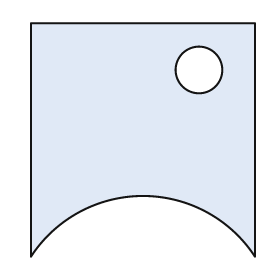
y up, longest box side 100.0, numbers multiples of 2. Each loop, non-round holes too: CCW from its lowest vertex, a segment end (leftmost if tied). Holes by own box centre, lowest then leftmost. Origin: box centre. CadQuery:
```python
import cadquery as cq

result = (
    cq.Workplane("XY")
    .moveTo(-48.0, -50.0)
    .threePointArc((0.0, -24.0), (48.0, -50.0))
    .lineTo(48.0, 50.0)
    .lineTo(-48.0, 50.0)
    .close()
    .moveTo(24.0, 30.0)
    .circle(10.0)
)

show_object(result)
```